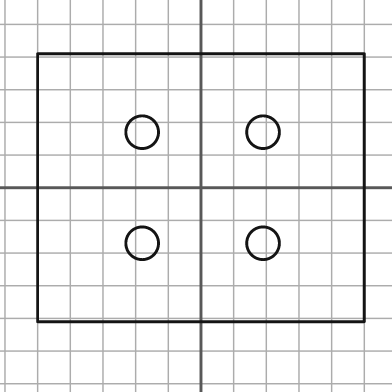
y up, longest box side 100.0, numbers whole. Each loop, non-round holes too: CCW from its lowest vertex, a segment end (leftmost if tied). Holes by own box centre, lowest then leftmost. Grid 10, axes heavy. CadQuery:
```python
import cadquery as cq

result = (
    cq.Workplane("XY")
    .moveTo(-50.0, -41.0)
    .lineTo(50.0, -41.0)
    .lineTo(50.0, 41.0)
    .lineTo(-50.0, 41.0)
    .close()
    .moveTo(-18.0, -17.0)
    .circle(5.0)
    .moveTo(19.0, -17.0)
    .circle(5.0)
    .moveTo(-18.0, 17.0)
    .circle(5.0)
    .moveTo(19.0, 17.0)
    .circle(5.0)
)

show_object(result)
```